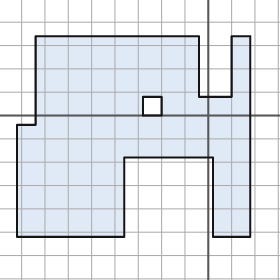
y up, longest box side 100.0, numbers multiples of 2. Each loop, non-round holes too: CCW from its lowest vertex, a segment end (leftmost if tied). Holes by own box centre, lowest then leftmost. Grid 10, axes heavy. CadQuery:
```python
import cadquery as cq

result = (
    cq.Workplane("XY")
    .moveTo(-82.0, -52.0)
    .lineTo(-36.0, -52.0)
    .lineTo(-36.0, -18.0)
    .lineTo(2.0, -18.0)
    .lineTo(2.0, -52.0)
    .lineTo(18.0, -52.0)
    .lineTo(18.0, 34.0)
    .lineTo(10.0, 34.0)
    .lineTo(10.0, 8.0)
    .lineTo(-4.0, 8.0)
    .lineTo(-4.0, 34.0)
    .lineTo(-74.0, 34.0)
    .lineTo(-74.0, -4.0)
    .lineTo(-82.0, -4.0)
    .close()
    .moveTo(-28.0, 0.0)
    .lineTo(-20.0, 0.0)
    .lineTo(-20.0, 8.0)
    .lineTo(-28.0, 8.0)
    .close()
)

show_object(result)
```